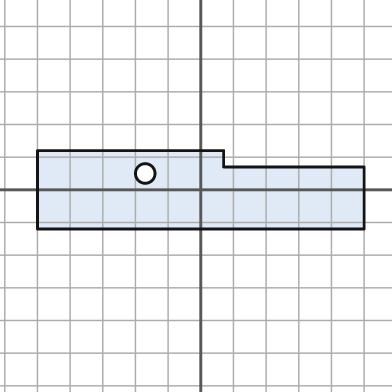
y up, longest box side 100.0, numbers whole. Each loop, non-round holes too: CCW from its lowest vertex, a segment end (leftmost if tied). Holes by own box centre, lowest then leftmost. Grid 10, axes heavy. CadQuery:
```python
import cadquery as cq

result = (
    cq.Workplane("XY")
    .moveTo(-50.0, -12.0)
    .lineTo(50.0, -12.0)
    .lineTo(50.0, 7.0)
    .lineTo(7.0, 7.0)
    .lineTo(7.0, 12.0)
    .lineTo(-50.0, 12.0)
    .close()
    .moveTo(-17.0, 5.0)
    .circle(3.0)
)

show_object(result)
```